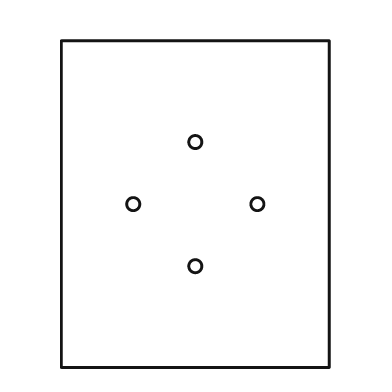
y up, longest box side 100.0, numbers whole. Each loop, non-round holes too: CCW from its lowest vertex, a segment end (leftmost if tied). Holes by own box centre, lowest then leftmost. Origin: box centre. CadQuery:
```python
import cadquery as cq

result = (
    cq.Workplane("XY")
    .moveTo(-41.0, -50.0)
    .lineTo(41.0, -50.0)
    .lineTo(41.0, 50.0)
    .lineTo(-41.0, 50.0)
    .close()
    .moveTo(0.0, -19.0)
    .circle(2.0)
    .moveTo(-19.0, 0.0)
    .circle(2.0)
    .moveTo(19.0, 0.0)
    .circle(2.0)
    .moveTo(0.0, 19.0)
    .circle(2.0)
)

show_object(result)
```